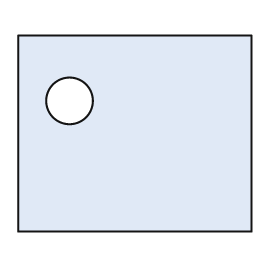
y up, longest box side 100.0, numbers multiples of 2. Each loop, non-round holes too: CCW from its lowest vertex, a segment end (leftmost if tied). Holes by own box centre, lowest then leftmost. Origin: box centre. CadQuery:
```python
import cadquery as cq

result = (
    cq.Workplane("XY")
    .moveTo(-50.0, -42.0)
    .lineTo(50.0, -42.0)
    .lineTo(50.0, 42.0)
    .lineTo(-50.0, 42.0)
    .close()
    .moveTo(-28.0, 14.0)
    .circle(10.0)
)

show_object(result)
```